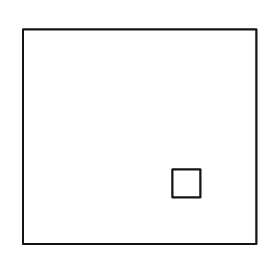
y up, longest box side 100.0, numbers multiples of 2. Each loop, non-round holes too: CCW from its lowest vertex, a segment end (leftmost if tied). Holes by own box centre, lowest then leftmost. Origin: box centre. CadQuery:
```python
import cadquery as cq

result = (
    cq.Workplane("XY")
    .moveTo(-50.0, -46.0)
    .lineTo(50.0, -46.0)
    .lineTo(50.0, 46.0)
    .lineTo(-50.0, 46.0)
    .close()
    .moveTo(14.0, -26.0)
    .lineTo(26.0, -26.0)
    .lineTo(26.0, -14.0)
    .lineTo(14.0, -14.0)
    .close()
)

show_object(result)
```